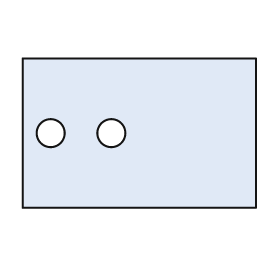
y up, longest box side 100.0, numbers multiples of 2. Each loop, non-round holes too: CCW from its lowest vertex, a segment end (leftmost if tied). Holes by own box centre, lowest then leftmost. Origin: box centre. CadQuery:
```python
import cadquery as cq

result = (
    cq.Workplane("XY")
    .moveTo(-50.0, -32.0)
    .lineTo(50.0, -32.0)
    .lineTo(50.0, 32.0)
    .lineTo(-50.0, 32.0)
    .close()
    .moveTo(-38.0, 0.0)
    .circle(6.0)
    .moveTo(-12.0, 0.0)
    .circle(6.0)
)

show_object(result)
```